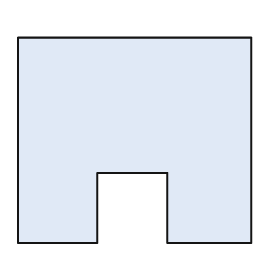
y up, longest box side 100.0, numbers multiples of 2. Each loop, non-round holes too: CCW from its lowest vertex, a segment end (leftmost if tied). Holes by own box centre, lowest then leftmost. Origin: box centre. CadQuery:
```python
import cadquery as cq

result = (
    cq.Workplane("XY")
    .moveTo(-50.0, -44.0)
    .lineTo(-16.0, -44.0)
    .lineTo(-16.0, -14.0)
    .lineTo(14.0, -14.0)
    .lineTo(14.0, -44.0)
    .lineTo(50.0, -44.0)
    .lineTo(50.0, 44.0)
    .lineTo(-50.0, 44.0)
    .close()
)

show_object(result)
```